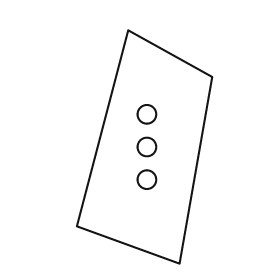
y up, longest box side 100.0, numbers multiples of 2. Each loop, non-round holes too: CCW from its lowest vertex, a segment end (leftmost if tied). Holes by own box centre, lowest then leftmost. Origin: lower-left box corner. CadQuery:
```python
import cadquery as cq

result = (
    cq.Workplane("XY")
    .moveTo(44.0, 0.0)
    .lineTo(58.0, 80.0)
    .lineTo(22.0, 100.0)
    .lineTo(0.0, 16.0)
    .close()
    .moveTo(30.0, 36.0)
    .circle(4.0)
    .moveTo(30.0, 50.0)
    .circle(4.0)
    .moveTo(30.0, 64.0)
    .circle(4.0)
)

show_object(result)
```